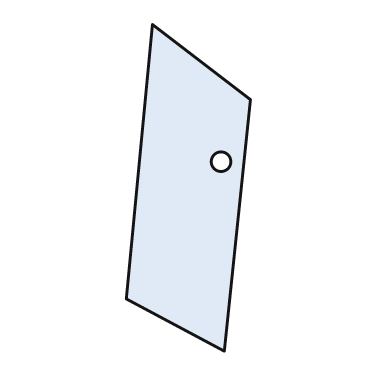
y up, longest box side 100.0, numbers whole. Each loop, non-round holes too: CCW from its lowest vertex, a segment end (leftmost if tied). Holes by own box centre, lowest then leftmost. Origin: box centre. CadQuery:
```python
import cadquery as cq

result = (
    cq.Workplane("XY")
    .moveTo(11.0, -50.0)
    .lineTo(19.0, 27.0)
    .lineTo(-11.0, 50.0)
    .lineTo(-19.0, -34.0)
    .close()
    .moveTo(10.0, 8.0)
    .circle(3.0)
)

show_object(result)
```